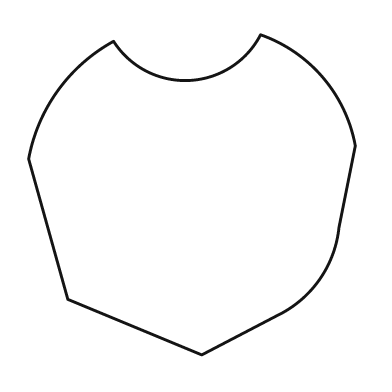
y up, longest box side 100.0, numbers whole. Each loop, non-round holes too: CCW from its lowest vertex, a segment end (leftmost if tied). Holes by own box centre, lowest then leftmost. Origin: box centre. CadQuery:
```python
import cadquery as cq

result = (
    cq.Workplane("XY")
    .moveTo(3.0, -49.0)
    .lineTo(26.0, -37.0)
    .threePointArc((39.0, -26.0), (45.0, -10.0))
    .lineTo(50.0, 15.0)
    .threePointArc((40.0, 36.0), (21.0, 49.0))
    .threePointArc((-1.0, 35.0), (-24.0, 47.0))
    .threePointArc((-41.0, 32.0), (-50.0, 11.0))
    .lineTo(-38.0, -32.0)
    .close()
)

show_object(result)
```